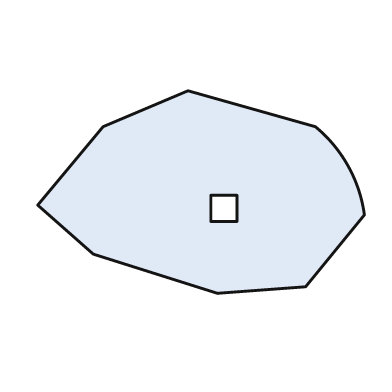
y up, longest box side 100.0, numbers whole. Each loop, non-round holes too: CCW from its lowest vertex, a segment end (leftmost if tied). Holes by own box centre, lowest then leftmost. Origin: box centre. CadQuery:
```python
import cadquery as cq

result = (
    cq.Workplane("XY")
    .moveTo(5.0, -31.0)
    .lineTo(32.0, -29.0)
    .lineTo(50.0, -7.0)
    .threePointArc((45.0, 8.0), (35.0, 20.0))
    .lineTo(-4.0, 31.0)
    .lineTo(-30.0, 20.0)
    .lineTo(-50.0, -4.0)
    .lineTo(-33.0, -19.0)
    .close()
    .moveTo(3.0, -9.0)
    .lineTo(11.0, -9.0)
    .lineTo(11.0, -1.0)
    .lineTo(3.0, -1.0)
    .close()
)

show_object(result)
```